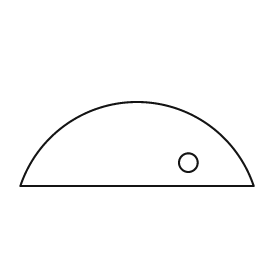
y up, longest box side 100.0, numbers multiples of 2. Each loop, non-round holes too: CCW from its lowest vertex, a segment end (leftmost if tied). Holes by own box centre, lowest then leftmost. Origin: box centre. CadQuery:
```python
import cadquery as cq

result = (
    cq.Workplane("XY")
    .moveTo(-50.0, -18.0)
    .lineTo(50.0, -18.0)
    .threePointArc((0.0, 18.0), (-50.0, -18.0))
    .close()
    .moveTo(22.0, -8.0)
    .circle(4.0)
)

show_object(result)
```